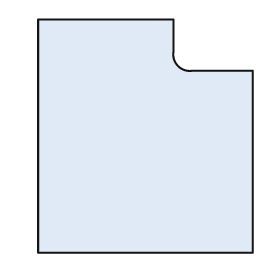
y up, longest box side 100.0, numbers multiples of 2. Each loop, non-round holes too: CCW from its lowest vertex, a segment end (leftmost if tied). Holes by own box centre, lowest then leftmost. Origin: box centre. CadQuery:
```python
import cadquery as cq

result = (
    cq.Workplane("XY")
    .moveTo(-46.0, -50.0)
    .lineTo(46.0, -50.0)
    .lineTo(46.0, 28.0)
    .lineTo(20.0, 28.0)
    .threePointArc((14.0, 30.0), (12.0, 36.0))
    .lineTo(12.0, 50.0)
    .lineTo(-46.0, 50.0)
    .close()
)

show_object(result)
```